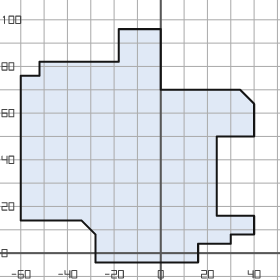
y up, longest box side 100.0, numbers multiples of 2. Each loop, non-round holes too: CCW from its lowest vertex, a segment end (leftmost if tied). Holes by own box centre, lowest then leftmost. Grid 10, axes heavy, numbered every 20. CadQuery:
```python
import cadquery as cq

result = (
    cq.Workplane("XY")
    .moveTo(-28.0, -4.0)
    .lineTo(16.0, -4.0)
    .lineTo(16.0, 4.0)
    .lineTo(30.0, 4.0)
    .lineTo(30.0, 8.0)
    .lineTo(40.0, 8.0)
    .lineTo(40.0, 16.0)
    .lineTo(24.0, 16.0)
    .lineTo(24.0, 50.0)
    .lineTo(40.0, 50.0)
    .lineTo(40.0, 64.0)
    .lineTo(34.0, 70.0)
    .lineTo(0.0, 70.0)
    .lineTo(0.0, 96.0)
    .lineTo(-18.0, 96.0)
    .lineTo(-18.0, 82.0)
    .lineTo(-52.0, 82.0)
    .lineTo(-52.0, 76.0)
    .lineTo(-60.0, 76.0)
    .lineTo(-60.0, 14.0)
    .lineTo(-34.0, 14.0)
    .lineTo(-28.0, 8.0)
    .close()
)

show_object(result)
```